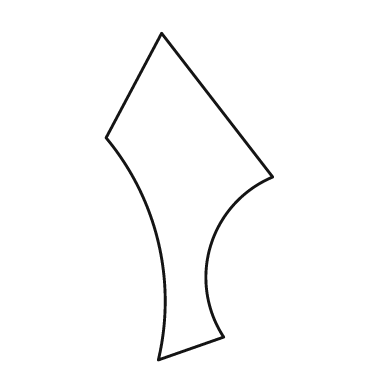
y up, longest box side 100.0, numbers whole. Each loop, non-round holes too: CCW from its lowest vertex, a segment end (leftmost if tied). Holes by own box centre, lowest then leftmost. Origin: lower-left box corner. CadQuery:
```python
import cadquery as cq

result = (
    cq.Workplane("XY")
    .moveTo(16.0, 0.0)
    .lineTo(36.0, 7.0)
    .threePointArc((32.0, 35.0), (51.0, 56.0))
    .lineTo(17.0, 100.0)
    .lineTo(0.0, 68.0)
    .threePointArc((16.0, 36.0), (16.0, 0.0))
    .close()
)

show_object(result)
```